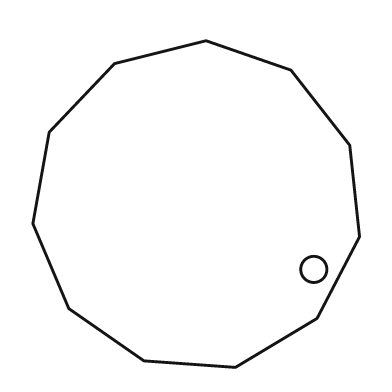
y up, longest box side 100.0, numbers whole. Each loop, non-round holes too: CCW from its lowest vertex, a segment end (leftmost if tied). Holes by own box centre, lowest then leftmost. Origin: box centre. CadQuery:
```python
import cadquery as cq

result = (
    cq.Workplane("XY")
    .moveTo(12.0, -50.0)
    .lineTo(37.0, -35.0)
    .lineTo(50.0, -10.0)
    .lineTo(47.0, 18.0)
    .lineTo(29.0, 41.0)
    .lineTo(3.0, 50.0)
    .lineTo(-25.0, 43.0)
    .lineTo(-45.0, 22.0)
    .lineTo(-50.0, -6.0)
    .lineTo(-39.0, -32.0)
    .lineTo(-16.0, -48.0)
    .close()
    .moveTo(36.0, -20.0)
    .circle(4.0)
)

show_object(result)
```